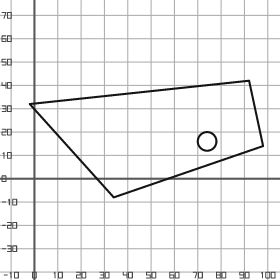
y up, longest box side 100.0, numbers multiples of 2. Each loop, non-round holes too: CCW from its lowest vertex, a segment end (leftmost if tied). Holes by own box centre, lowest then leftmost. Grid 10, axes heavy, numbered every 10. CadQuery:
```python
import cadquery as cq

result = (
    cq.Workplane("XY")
    .moveTo(34.0, -8.0)
    .lineTo(98.0, 14.0)
    .lineTo(92.0, 42.0)
    .lineTo(-2.0, 32.0)
    .close()
    .moveTo(74.0, 16.0)
    .circle(4.0)
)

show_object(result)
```